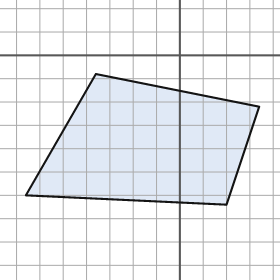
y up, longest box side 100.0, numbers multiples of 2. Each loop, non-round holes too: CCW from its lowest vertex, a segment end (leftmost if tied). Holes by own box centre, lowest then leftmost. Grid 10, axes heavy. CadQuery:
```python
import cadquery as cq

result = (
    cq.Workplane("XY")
    .moveTo(20.0, -64.0)
    .lineTo(34.0, -22.0)
    .lineTo(-36.0, -8.0)
    .lineTo(-66.0, -60.0)
    .close()
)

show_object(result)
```